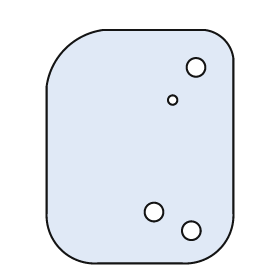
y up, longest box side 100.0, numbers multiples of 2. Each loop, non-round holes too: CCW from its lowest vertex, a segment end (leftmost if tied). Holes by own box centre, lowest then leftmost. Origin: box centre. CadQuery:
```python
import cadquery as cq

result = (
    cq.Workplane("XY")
    .moveTo(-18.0, -50.0)
    .lineTo(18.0, -50.0)
    .threePointArc((34.0, -44.0), (40.0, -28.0))
    .lineTo(40.0, 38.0)
    .threePointArc((36.0, 46.0), (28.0, 50.0))
    .lineTo(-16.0, 50.0)
    .threePointArc((-32.0, 42.0), (-40.0, 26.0))
    .lineTo(-40.0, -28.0)
    .threePointArc((-34.0, -44.0), (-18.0, -50.0))
    .close()
    .moveTo(22.0, -36.0)
    .circle(4.0)
    .moveTo(6.0, -28.0)
    .circle(4.0)
    .moveTo(14.0, 20.0)
    .circle(2.0)
    .moveTo(24.0, 34.0)
    .circle(4.0)
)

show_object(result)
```